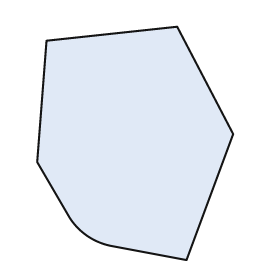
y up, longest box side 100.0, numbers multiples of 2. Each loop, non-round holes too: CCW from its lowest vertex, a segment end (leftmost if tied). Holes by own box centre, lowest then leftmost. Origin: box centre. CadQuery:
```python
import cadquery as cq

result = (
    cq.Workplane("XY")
    .moveTo(22.0, -50.0)
    .lineTo(42.0, 4.0)
    .lineTo(18.0, 50.0)
    .lineTo(-38.0, 44.0)
    .lineTo(-42.0, -8.0)
    .lineTo(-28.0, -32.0)
    .threePointArc((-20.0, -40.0), (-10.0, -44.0))
    .close()
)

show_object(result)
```